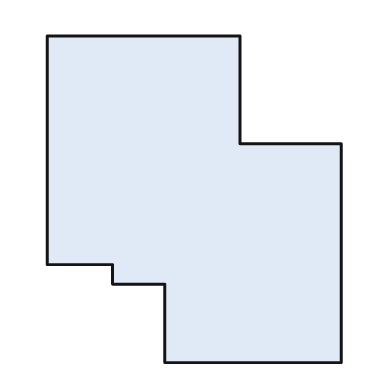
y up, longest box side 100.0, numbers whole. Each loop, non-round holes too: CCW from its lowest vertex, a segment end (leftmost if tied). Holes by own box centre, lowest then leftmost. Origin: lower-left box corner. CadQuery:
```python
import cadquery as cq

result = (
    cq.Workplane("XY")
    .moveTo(36.0, 0.0)
    .lineTo(90.0, 0.0)
    .lineTo(90.0, 67.0)
    .lineTo(59.0, 67.0)
    .lineTo(59.0, 100.0)
    .lineTo(0.0, 100.0)
    .lineTo(0.0, 30.0)
    .lineTo(20.0, 30.0)
    .lineTo(20.0, 24.0)
    .lineTo(36.0, 24.0)
    .close()
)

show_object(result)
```